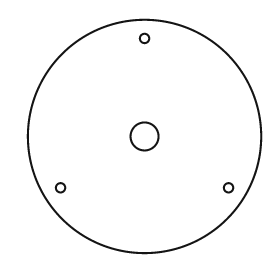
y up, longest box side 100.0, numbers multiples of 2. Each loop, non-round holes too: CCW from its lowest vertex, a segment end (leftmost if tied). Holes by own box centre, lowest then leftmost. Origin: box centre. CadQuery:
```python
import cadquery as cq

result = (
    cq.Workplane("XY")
    .moveTo(0.0, 0.0)
    .circle(50.0)
    .moveTo(-36.0, -22.0)
    .circle(2.0)
    .moveTo(36.0, -22.0)
    .circle(2.0)
    .moveTo(0.0, 0.0)
    .circle(6.0)
    .moveTo(0.0, 42.0)
    .circle(2.0)
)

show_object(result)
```